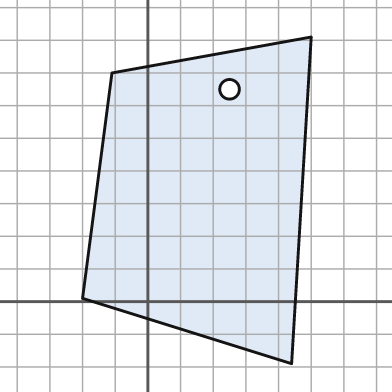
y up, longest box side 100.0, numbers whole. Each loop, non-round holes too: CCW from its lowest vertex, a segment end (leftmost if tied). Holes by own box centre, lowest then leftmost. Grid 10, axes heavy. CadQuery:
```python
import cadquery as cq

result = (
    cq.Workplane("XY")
    .moveTo(44.0, -19.0)
    .lineTo(50.0, 81.0)
    .lineTo(-11.0, 70.0)
    .lineTo(-20.0, 1.0)
    .close()
    .moveTo(25.0, 65.0)
    .circle(3.0)
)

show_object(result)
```